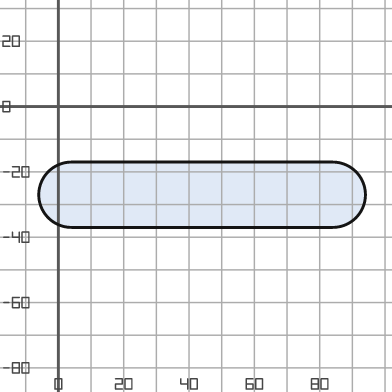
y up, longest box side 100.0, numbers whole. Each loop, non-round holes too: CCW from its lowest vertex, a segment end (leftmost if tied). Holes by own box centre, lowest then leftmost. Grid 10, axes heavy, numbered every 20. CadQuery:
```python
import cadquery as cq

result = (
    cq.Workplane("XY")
    .moveTo(4.0, -37.0)
    .lineTo(84.0, -37.0)
    .threePointArc((94.0, -27.0), (84.0, -17.0))
    .lineTo(4.0, -17.0)
    .threePointArc((-6.0, -27.0), (4.0, -37.0))
    .close()
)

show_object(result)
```